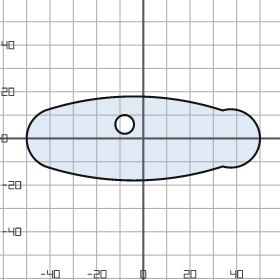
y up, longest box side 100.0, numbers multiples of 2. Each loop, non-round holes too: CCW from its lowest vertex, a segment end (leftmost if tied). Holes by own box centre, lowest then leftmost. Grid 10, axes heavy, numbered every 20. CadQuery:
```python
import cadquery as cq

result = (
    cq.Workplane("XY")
    .moveTo(-42.0, -12.0)
    .threePointArc((-4.0, -18.0), (34.0, -12.0))
    .threePointArc((50.0, 0.0), (34.0, 12.0))
    .threePointArc((-4.0, 18.0), (-42.0, 12.0))
    .threePointArc((-50.0, 0.0), (-42.0, -12.0))
    .close()
    .moveTo(-8.0, 6.0)
    .circle(4.0)
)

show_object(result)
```